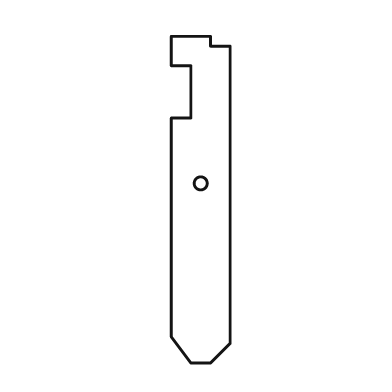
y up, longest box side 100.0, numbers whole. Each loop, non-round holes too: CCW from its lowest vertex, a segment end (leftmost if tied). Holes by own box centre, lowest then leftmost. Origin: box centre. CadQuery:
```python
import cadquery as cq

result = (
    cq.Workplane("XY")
    .moveTo(-3.0, -50.0)
    .lineTo(3.0, -50.0)
    .lineTo(9.0, -44.0)
    .lineTo(9.0, 47.0)
    .lineTo(3.0, 47.0)
    .lineTo(3.0, 50.0)
    .lineTo(-9.0, 50.0)
    .lineTo(-9.0, 41.0)
    .lineTo(-3.0, 41.0)
    .lineTo(-3.0, 25.0)
    .lineTo(-9.0, 25.0)
    .lineTo(-9.0, -42.0)
    .close()
    .moveTo(0.0, 5.0)
    .circle(2.0)
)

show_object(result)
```